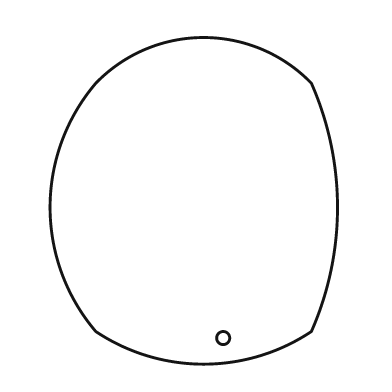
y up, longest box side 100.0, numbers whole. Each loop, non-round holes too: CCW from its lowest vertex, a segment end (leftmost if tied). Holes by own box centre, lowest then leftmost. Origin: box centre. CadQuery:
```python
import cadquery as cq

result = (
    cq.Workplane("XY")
    .moveTo(-30.0, -40.0)
    .threePointArc((3.0, -50.0), (36.0, -40.0))
    .threePointArc((44.0, -2.0), (36.0, 36.0))
    .threePointArc((3.0, 50.0), (-30.0, 36.0))
    .threePointArc((-44.0, -2.0), (-30.0, -40.0))
    .close()
    .moveTo(9.0, -42.0)
    .circle(2.0)
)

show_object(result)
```